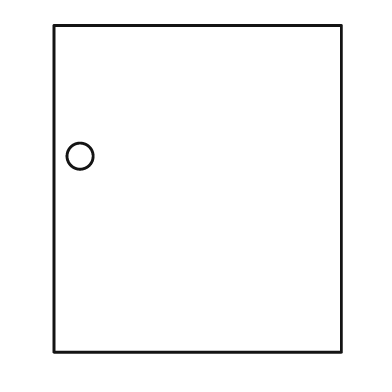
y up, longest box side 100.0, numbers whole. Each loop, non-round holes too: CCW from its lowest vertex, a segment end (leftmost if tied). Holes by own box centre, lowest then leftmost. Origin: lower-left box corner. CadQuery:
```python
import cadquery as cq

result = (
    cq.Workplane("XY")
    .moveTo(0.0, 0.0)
    .lineTo(88.0, 0.0)
    .lineTo(88.0, 100.0)
    .lineTo(0.0, 100.0)
    .close()
    .moveTo(8.0, 60.0)
    .circle(4.0)
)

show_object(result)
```